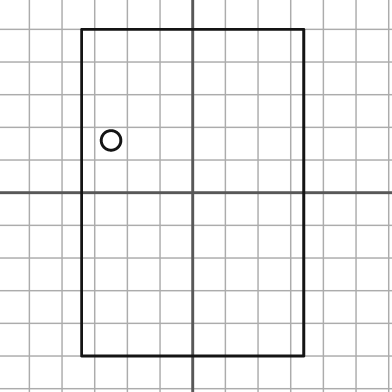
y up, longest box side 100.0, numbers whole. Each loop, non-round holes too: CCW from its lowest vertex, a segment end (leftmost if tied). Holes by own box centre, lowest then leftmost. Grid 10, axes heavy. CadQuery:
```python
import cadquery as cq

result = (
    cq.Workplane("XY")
    .moveTo(-34.0, -50.0)
    .lineTo(34.0, -50.0)
    .lineTo(34.0, 50.0)
    .lineTo(-34.0, 50.0)
    .close()
    .moveTo(-25.0, 16.0)
    .circle(3.0)
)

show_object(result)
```